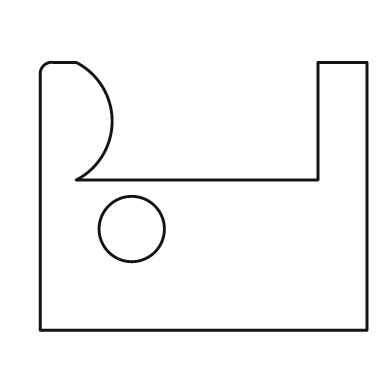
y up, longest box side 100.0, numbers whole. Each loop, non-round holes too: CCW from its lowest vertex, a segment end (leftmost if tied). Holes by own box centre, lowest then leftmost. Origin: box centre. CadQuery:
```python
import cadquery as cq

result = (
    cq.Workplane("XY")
    .moveTo(-50.0, -41.0)
    .lineTo(50.0, -41.0)
    .lineTo(50.0, 41.0)
    .lineTo(35.0, 41.0)
    .lineTo(35.0, 5.0)
    .lineTo(-39.0, 5.0)
    .threePointArc((-28.0, 23.0), (-39.0, 41.0))
    .lineTo(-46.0, 41.0)
    .threePointArc((-49.0, 40.0), (-50.0, 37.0))
    .close()
    .moveTo(-22.0, -10.0)
    .circle(10.0)
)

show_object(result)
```